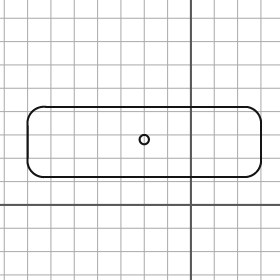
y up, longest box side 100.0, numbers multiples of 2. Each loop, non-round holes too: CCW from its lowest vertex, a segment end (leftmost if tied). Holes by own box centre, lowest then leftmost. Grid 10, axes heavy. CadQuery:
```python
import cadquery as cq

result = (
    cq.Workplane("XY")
    .moveTo(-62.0, 12.0)
    .lineTo(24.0, 12.0)
    .threePointArc((28.0, 14.0), (30.0, 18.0))
    .lineTo(30.0, 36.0)
    .threePointArc((28.0, 40.0), (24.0, 42.0))
    .lineTo(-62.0, 42.0)
    .threePointArc((-68.0, 40.0), (-70.0, 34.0))
    .lineTo(-70.0, 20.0)
    .threePointArc((-68.0, 14.0), (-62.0, 12.0))
    .close()
    .moveTo(-20.0, 28.0)
    .circle(2.0)
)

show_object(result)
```